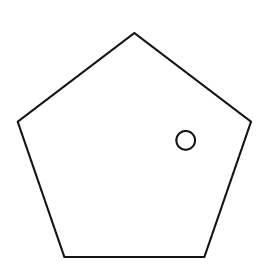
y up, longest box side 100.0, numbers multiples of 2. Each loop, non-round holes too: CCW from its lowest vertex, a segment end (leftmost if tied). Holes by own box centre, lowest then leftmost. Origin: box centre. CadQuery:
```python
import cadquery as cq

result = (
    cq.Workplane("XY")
    .moveTo(-30.0, -48.0)
    .lineTo(30.0, -48.0)
    .lineTo(50.0, 10.0)
    .lineTo(0.0, 48.0)
    .lineTo(-50.0, 10.0)
    .close()
    .moveTo(22.0, 2.0)
    .circle(4.0)
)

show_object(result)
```